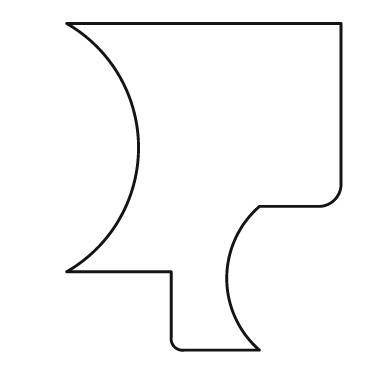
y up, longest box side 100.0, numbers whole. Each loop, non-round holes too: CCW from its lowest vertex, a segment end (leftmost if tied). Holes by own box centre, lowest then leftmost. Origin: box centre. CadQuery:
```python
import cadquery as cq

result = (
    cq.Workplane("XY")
    .moveTo(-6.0, -50.0)
    .lineTo(17.0, -50.0)
    .threePointArc((7.0, -28.0), (17.0, -6.0))
    .lineTo(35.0, -6.0)
    .threePointArc((40.0, -4.0), (42.0, 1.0))
    .lineTo(42.0, 50.0)
    .lineTo(-42.0, 50.0)
    .threePointArc((-20.0, 12.0), (-42.0, -26.0))
    .lineTo(-10.0, -26.0)
    .lineTo(-10.0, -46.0)
    .threePointArc((-9.0, -49.0), (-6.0, -50.0))
    .close()
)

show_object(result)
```